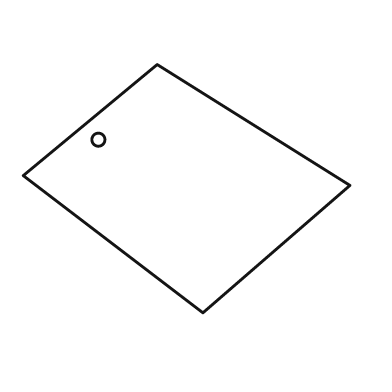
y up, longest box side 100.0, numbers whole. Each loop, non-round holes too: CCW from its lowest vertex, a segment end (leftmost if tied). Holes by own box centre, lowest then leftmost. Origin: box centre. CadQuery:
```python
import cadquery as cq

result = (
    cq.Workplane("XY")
    .moveTo(5.0, -38.0)
    .lineTo(50.0, 1.0)
    .lineTo(-9.0, 38.0)
    .lineTo(-50.0, 4.0)
    .close()
    .moveTo(-27.0, 15.0)
    .circle(2.0)
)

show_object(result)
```